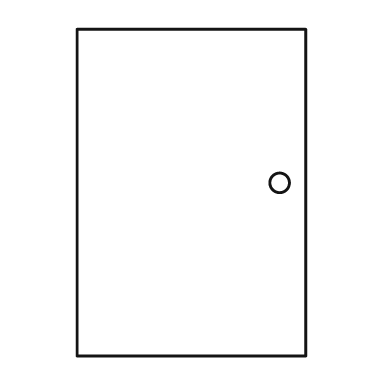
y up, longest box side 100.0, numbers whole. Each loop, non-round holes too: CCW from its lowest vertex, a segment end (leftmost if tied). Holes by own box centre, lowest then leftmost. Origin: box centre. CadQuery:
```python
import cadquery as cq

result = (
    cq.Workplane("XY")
    .moveTo(-35.0, -50.0)
    .lineTo(35.0, -50.0)
    .lineTo(35.0, 50.0)
    .lineTo(-35.0, 50.0)
    .close()
    .moveTo(27.0, 3.0)
    .circle(3.0)
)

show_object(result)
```